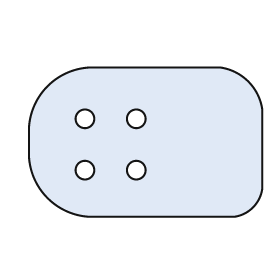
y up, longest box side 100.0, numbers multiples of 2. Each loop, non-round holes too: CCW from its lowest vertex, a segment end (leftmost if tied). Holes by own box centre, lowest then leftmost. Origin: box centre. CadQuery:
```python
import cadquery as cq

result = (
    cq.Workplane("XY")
    .moveTo(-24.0, -32.0)
    .lineTo(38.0, -32.0)
    .threePointArc((46.0, -28.0), (50.0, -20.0))
    .lineTo(50.0, 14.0)
    .threePointArc((44.0, 26.0), (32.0, 32.0))
    .lineTo(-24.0, 32.0)
    .threePointArc((-42.0, 24.0), (-50.0, 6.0))
    .lineTo(-50.0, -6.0)
    .threePointArc((-42.0, -24.0), (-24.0, -32.0))
    .close()
    .moveTo(-26.0, -12.0)
    .circle(4.0)
    .moveTo(-4.0, -12.0)
    .circle(4.0)
    .moveTo(-26.0, 10.0)
    .circle(4.0)
    .moveTo(-4.0, 10.0)
    .circle(4.0)
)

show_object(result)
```